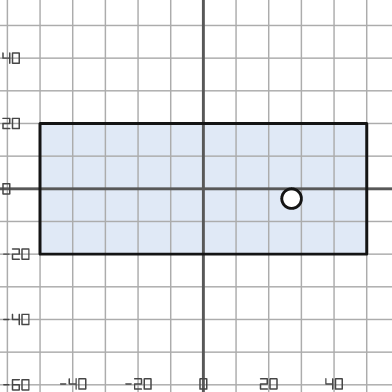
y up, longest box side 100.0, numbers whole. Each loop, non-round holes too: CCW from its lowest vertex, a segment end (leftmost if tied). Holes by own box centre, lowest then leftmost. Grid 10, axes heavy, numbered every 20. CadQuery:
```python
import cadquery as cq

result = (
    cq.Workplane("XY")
    .moveTo(-50.0, -20.0)
    .lineTo(50.0, -20.0)
    .lineTo(50.0, 20.0)
    .lineTo(-50.0, 20.0)
    .close()
    .moveTo(27.0, -3.0)
    .circle(3.0)
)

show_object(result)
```